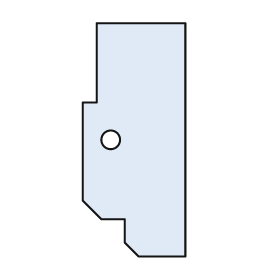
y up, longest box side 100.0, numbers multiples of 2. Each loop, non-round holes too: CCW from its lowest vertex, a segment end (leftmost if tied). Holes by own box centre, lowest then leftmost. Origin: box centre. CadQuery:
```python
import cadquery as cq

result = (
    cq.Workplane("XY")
    .moveTo(2.0, -50.0)
    .lineTo(22.0, -50.0)
    .lineTo(22.0, 50.0)
    .lineTo(-16.0, 50.0)
    .lineTo(-16.0, 16.0)
    .lineTo(-22.0, 16.0)
    .lineTo(-22.0, -26.0)
    .lineTo(-14.0, -34.0)
    .lineTo(-4.0, -34.0)
    .lineTo(-4.0, -44.0)
    .close()
    .moveTo(-10.0, 0.0)
    .circle(4.0)
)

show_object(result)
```